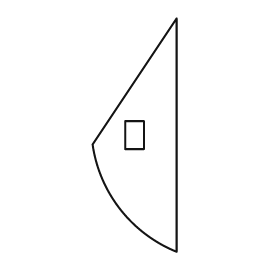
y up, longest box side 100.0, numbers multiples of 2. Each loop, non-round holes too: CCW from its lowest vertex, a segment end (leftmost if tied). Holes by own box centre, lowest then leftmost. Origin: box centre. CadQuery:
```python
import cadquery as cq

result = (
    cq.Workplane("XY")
    .moveTo(18.0, -50.0)
    .lineTo(18.0, 50.0)
    .lineTo(-18.0, -4.0)
    .threePointArc((-6.0, -32.0), (18.0, -50.0))
    .close()
    .moveTo(-4.0, -6.0)
    .lineTo(4.0, -6.0)
    .lineTo(4.0, 6.0)
    .lineTo(-4.0, 6.0)
    .close()
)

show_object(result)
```